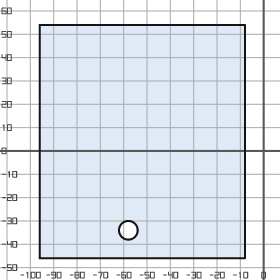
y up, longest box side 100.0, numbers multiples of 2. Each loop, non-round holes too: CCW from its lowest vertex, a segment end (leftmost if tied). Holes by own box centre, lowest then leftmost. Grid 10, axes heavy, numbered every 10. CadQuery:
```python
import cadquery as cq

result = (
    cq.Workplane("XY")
    .moveTo(-96.0, -46.0)
    .lineTo(-8.0, -46.0)
    .lineTo(-8.0, 54.0)
    .lineTo(-96.0, 54.0)
    .close()
    .moveTo(-58.0, -34.0)
    .circle(4.0)
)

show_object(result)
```